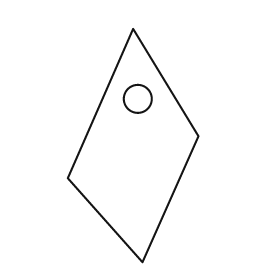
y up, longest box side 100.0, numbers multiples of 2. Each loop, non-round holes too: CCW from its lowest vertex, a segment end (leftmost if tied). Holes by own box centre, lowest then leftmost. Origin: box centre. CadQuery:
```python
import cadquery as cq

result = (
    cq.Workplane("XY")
    .moveTo(4.0, -50.0)
    .lineTo(28.0, 4.0)
    .lineTo(0.0, 50.0)
    .lineTo(-28.0, -14.0)
    .close()
    .moveTo(2.0, 20.0)
    .circle(6.0)
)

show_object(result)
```